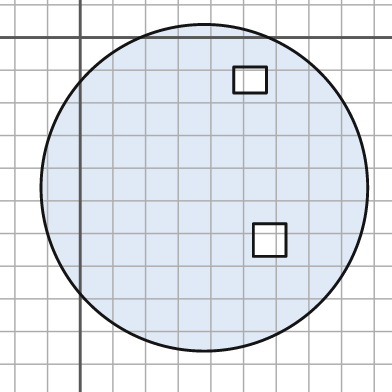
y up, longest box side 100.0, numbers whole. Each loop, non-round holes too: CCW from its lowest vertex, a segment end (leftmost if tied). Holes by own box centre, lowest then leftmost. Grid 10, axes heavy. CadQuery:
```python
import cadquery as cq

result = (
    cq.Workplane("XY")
    .moveTo(38.0, -46.0)
    .circle(50.0)
    .moveTo(53.0, -67.0)
    .lineTo(63.0, -67.0)
    .lineTo(63.0, -57.0)
    .lineTo(53.0, -57.0)
    .close()
    .moveTo(47.0, -17.0)
    .lineTo(57.0, -17.0)
    .lineTo(57.0, -9.0)
    .lineTo(47.0, -9.0)
    .close()
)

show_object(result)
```